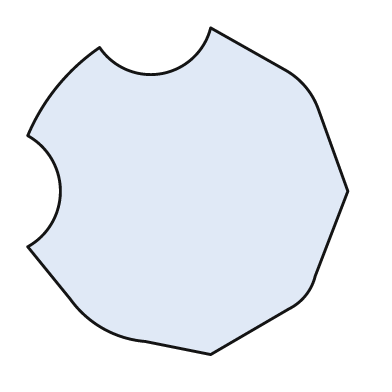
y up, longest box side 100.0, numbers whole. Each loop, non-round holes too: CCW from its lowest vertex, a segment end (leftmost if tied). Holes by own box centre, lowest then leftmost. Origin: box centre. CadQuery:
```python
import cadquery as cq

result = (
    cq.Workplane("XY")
    .moveTo(7.0, -50.0)
    .lineTo(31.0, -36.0)
    .threePointArc((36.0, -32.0), (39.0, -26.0))
    .lineTo(49.0, 0.0)
    .lineTo(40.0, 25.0)
    .threePointArc((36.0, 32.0), (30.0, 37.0))
    .lineTo(7.0, 50.0)
    .threePointArc((-8.0, 36.0), (-27.0, 44.0))
    .threePointArc((-40.0, 32.0), (-49.0, 17.0))
    .threePointArc((-39.0, 0.0), (-49.0, -17.0))
    .lineTo(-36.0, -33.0)
    .threePointArc((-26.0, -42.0), (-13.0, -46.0))
    .close()
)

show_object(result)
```